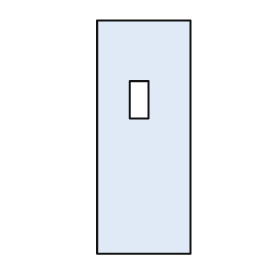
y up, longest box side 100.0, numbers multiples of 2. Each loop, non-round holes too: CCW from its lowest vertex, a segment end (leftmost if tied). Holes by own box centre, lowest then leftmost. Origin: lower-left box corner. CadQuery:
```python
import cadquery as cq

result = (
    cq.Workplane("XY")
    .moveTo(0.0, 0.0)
    .lineTo(40.0, 0.0)
    .lineTo(40.0, 100.0)
    .lineTo(0.0, 100.0)
    .close()
    .moveTo(14.0, 58.0)
    .lineTo(22.0, 58.0)
    .lineTo(22.0, 74.0)
    .lineTo(14.0, 74.0)
    .close()
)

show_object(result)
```